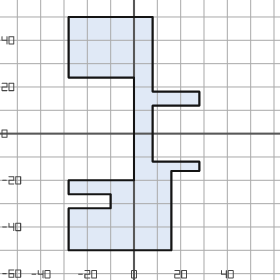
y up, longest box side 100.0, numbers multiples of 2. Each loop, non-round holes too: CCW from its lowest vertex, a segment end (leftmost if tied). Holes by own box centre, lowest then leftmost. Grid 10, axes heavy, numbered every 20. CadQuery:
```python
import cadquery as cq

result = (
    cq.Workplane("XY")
    .moveTo(-28.0, -50.0)
    .lineTo(16.0, -50.0)
    .lineTo(16.0, -16.0)
    .lineTo(28.0, -16.0)
    .lineTo(28.0, -12.0)
    .lineTo(8.0, -12.0)
    .lineTo(8.0, 12.0)
    .lineTo(28.0, 12.0)
    .lineTo(28.0, 18.0)
    .lineTo(8.0, 18.0)
    .lineTo(8.0, 50.0)
    .lineTo(-28.0, 50.0)
    .lineTo(-28.0, 24.0)
    .lineTo(0.0, 24.0)
    .lineTo(0.0, -20.0)
    .lineTo(-28.0, -20.0)
    .lineTo(-28.0, -26.0)
    .lineTo(-10.0, -26.0)
    .lineTo(-10.0, -32.0)
    .lineTo(-28.0, -32.0)
    .close()
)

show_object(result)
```